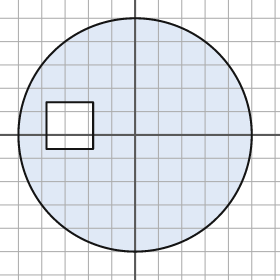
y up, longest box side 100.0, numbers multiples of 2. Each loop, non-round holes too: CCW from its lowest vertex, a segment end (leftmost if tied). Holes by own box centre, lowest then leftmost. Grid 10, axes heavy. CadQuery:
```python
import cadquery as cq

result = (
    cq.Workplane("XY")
    .moveTo(0.0, 0.0)
    .circle(50.0)
    .moveTo(-38.0, -6.0)
    .lineTo(-18.0, -6.0)
    .lineTo(-18.0, 14.0)
    .lineTo(-38.0, 14.0)
    .close()
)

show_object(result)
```